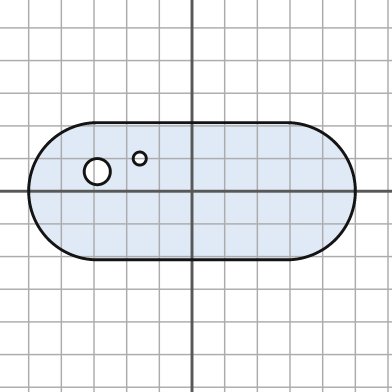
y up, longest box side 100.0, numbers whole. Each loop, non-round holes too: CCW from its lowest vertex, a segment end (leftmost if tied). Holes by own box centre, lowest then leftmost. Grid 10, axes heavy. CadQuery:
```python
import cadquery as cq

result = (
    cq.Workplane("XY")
    .moveTo(-29.0, -21.0)
    .lineTo(29.0, -21.0)
    .threePointArc((50.0, 0.0), (29.0, 21.0))
    .lineTo(-29.0, 21.0)
    .threePointArc((-50.0, 0.0), (-29.0, -21.0))
    .close()
    .moveTo(-29.0, 6.0)
    .circle(4.0)
    .moveTo(-16.0, 10.0)
    .circle(2.0)
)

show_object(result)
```